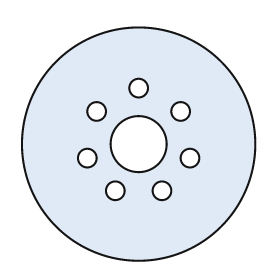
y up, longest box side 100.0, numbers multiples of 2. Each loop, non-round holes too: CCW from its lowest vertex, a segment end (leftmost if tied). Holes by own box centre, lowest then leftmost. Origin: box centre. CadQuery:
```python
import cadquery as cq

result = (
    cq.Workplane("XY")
    .moveTo(0.0, 0.0)
    .circle(50.0)
    .moveTo(-10.0, -20.0)
    .circle(4.0)
    .moveTo(10.0, -20.0)
    .circle(4.0)
    .moveTo(-22.0, -6.0)
    .circle(4.0)
    .moveTo(22.0, -6.0)
    .circle(4.0)
    .moveTo(0.0, 0.0)
    .circle(12.0)
    .moveTo(-18.0, 14.0)
    .circle(4.0)
    .moveTo(18.0, 14.0)
    .circle(4.0)
    .moveTo(0.0, 24.0)
    .circle(4.0)
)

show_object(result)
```